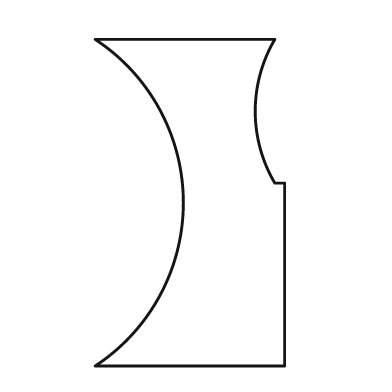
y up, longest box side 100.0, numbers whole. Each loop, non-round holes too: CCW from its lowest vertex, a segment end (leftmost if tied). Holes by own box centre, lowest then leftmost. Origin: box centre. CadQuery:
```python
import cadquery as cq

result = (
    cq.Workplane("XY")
    .moveTo(-29.0, -50.0)
    .lineTo(29.0, -50.0)
    .lineTo(29.0, 6.0)
    .lineTo(26.0, 6.0)
    .threePointArc((20.0, 28.0), (26.0, 50.0))
    .lineTo(-29.0, 50.0)
    .threePointArc((-2.0, 0.0), (-29.0, -50.0))
    .close()
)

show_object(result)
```